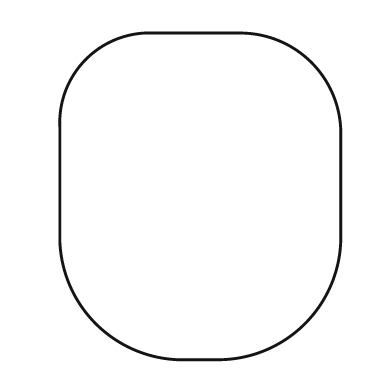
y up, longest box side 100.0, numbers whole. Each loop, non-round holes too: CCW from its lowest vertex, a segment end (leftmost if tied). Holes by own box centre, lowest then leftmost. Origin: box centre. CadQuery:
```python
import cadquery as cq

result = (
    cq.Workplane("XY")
    .moveTo(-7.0, -50.0)
    .lineTo(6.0, -50.0)
    .threePointArc((32.0, -39.0), (43.0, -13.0))
    .lineTo(43.0, 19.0)
    .threePointArc((34.0, 41.0), (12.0, 50.0))
    .lineTo(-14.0, 50.0)
    .threePointArc((-35.0, 42.0), (-43.0, 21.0))
    .lineTo(-43.0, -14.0)
    .threePointArc((-32.0, -39.0), (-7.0, -50.0))
    .close()
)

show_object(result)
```